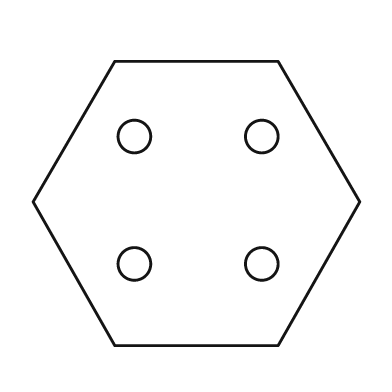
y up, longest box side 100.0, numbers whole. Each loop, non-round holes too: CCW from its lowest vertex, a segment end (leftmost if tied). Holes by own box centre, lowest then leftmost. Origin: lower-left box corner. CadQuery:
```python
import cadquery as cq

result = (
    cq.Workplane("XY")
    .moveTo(25.0, 0.0)
    .lineTo(75.0, 0.0)
    .lineTo(100.0, 44.0)
    .lineTo(75.0, 87.0)
    .lineTo(25.0, 87.0)
    .lineTo(0.0, 44.0)
    .close()
    .moveTo(31.0, 25.0)
    .circle(5.0)
    .moveTo(70.0, 25.0)
    .circle(5.0)
    .moveTo(31.0, 64.0)
    .circle(5.0)
    .moveTo(70.0, 64.0)
    .circle(5.0)
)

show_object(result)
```